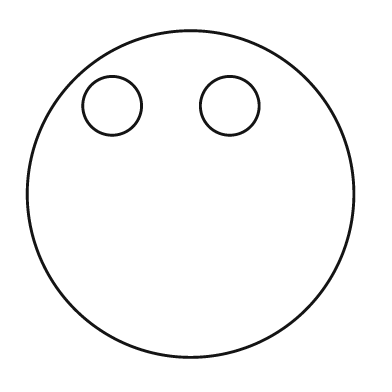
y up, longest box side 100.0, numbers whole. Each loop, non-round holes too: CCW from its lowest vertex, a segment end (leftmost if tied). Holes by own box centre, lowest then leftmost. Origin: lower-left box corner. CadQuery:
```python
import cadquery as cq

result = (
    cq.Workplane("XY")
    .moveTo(50.0, 50.0)
    .circle(50.0)
    .moveTo(26.0, 77.0)
    .circle(9.0)
    .moveTo(62.0, 77.0)
    .circle(9.0)
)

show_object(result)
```